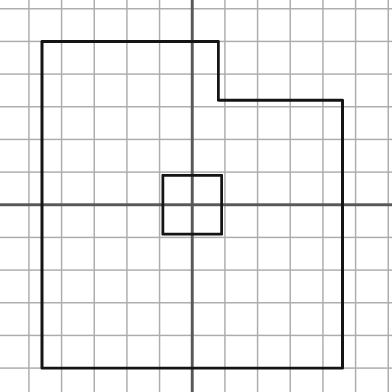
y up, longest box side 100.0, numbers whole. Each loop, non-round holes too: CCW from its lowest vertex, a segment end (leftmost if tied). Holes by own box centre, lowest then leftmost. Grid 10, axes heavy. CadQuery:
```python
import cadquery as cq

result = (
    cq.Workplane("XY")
    .moveTo(-46.0, -50.0)
    .lineTo(46.0, -50.0)
    .lineTo(46.0, 32.0)
    .lineTo(8.0, 32.0)
    .lineTo(8.0, 50.0)
    .lineTo(-46.0, 50.0)
    .close()
    .moveTo(-9.0, -9.0)
    .lineTo(9.0, -9.0)
    .lineTo(9.0, 9.0)
    .lineTo(-9.0, 9.0)
    .close()
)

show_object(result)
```